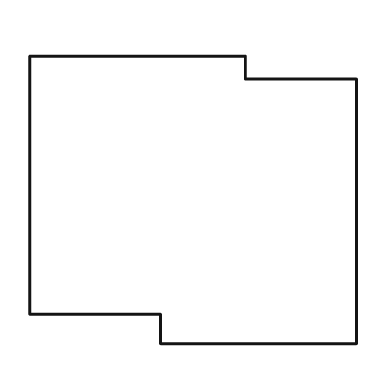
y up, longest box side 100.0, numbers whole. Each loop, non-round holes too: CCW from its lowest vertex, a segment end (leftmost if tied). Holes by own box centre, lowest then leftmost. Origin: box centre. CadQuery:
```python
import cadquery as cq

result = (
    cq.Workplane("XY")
    .moveTo(-10.0, -44.0)
    .lineTo(50.0, -44.0)
    .lineTo(50.0, 37.0)
    .lineTo(16.0, 37.0)
    .lineTo(16.0, 44.0)
    .lineTo(-50.0, 44.0)
    .lineTo(-50.0, -35.0)
    .lineTo(-10.0, -35.0)
    .close()
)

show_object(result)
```